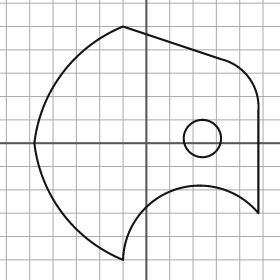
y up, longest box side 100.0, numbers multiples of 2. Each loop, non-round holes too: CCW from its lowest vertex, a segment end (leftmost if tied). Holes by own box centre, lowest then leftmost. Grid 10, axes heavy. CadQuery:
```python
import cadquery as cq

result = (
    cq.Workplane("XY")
    .moveTo(-10.0, -50.0)
    .threePointArc((12.0, -20.0), (48.0, -30.0))
    .lineTo(48.0, 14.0)
    .threePointArc((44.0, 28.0), (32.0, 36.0))
    .lineTo(-10.0, 50.0)
    .threePointArc((-36.0, 30.0), (-48.0, 0.0))
    .threePointArc((-36.0, -30.0), (-10.0, -50.0))
    .close()
    .moveTo(24.0, 2.0)
    .circle(8.0)
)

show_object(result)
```